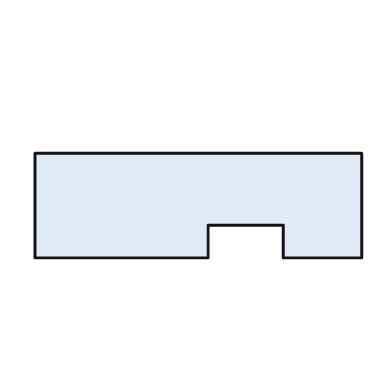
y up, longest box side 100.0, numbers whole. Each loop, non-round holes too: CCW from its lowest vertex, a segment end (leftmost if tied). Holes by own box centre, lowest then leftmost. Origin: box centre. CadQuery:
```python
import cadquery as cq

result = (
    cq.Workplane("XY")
    .moveTo(-50.0, -16.0)
    .lineTo(3.0, -16.0)
    .lineTo(3.0, -6.0)
    .lineTo(26.0, -6.0)
    .lineTo(26.0, -16.0)
    .lineTo(50.0, -16.0)
    .lineTo(50.0, 16.0)
    .lineTo(-50.0, 16.0)
    .close()
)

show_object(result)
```